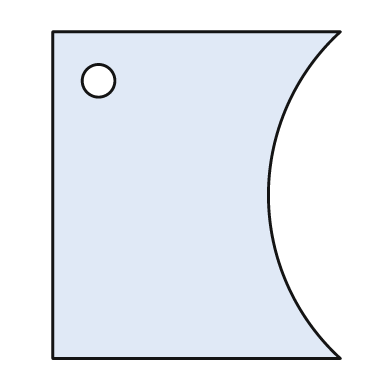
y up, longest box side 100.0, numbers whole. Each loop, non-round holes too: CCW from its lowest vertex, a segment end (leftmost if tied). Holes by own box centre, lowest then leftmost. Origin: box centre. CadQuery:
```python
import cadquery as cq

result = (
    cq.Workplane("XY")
    .moveTo(-44.0, -50.0)
    .lineTo(44.0, -50.0)
    .threePointArc((22.0, 0.0), (44.0, 50.0))
    .lineTo(-44.0, 50.0)
    .close()
    .moveTo(-30.0, 35.0)
    .circle(5.0)
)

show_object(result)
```